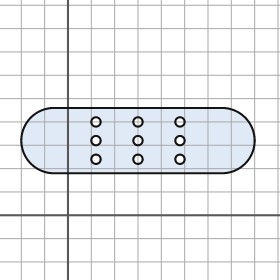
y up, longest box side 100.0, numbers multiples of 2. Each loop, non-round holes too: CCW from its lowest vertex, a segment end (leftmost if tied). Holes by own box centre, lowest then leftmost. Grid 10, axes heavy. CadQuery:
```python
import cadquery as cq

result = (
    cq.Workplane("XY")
    .moveTo(-6.0, 18.0)
    .lineTo(66.0, 18.0)
    .threePointArc((80.0, 32.0), (66.0, 46.0))
    .lineTo(-6.0, 46.0)
    .threePointArc((-20.0, 32.0), (-6.0, 18.0))
    .close()
    .moveTo(12.0, 24.0)
    .circle(2.0)
    .moveTo(30.0, 24.0)
    .circle(2.0)
    .moveTo(48.0, 24.0)
    .circle(2.0)
    .moveTo(12.0, 32.0)
    .circle(2.0)
    .moveTo(30.0, 32.0)
    .circle(2.0)
    .moveTo(48.0, 32.0)
    .circle(2.0)
    .moveTo(12.0, 40.0)
    .circle(2.0)
    .moveTo(30.0, 40.0)
    .circle(2.0)
    .moveTo(48.0, 40.0)
    .circle(2.0)
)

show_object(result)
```